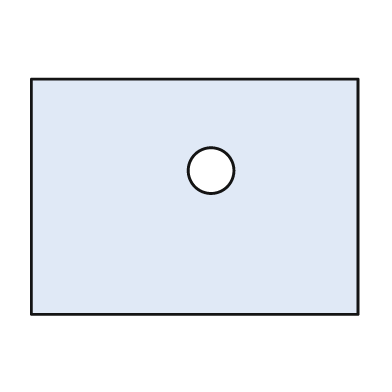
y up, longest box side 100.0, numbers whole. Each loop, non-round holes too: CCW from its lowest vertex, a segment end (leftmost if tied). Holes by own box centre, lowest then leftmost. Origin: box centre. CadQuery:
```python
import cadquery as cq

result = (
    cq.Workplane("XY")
    .moveTo(-50.0, -36.0)
    .lineTo(50.0, -36.0)
    .lineTo(50.0, 36.0)
    .lineTo(-50.0, 36.0)
    .close()
    .moveTo(5.0, 8.0)
    .circle(7.0)
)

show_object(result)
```